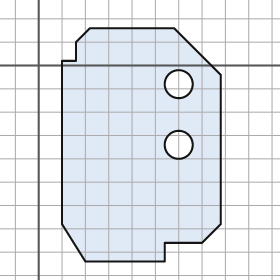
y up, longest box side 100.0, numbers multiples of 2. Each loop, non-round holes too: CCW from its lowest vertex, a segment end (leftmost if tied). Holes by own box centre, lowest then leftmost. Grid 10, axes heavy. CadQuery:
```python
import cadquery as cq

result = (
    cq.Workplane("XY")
    .moveTo(20.0, -84.0)
    .lineTo(54.0, -84.0)
    .lineTo(54.0, -76.0)
    .lineTo(70.0, -76.0)
    .lineTo(78.0, -68.0)
    .lineTo(78.0, -4.0)
    .lineTo(58.0, 16.0)
    .lineTo(22.0, 16.0)
    .lineTo(16.0, 10.0)
    .lineTo(16.0, 2.0)
    .lineTo(10.0, 2.0)
    .lineTo(10.0, -68.0)
    .close()
    .moveTo(60.0, -34.0)
    .circle(6.0)
    .moveTo(60.0, -8.0)
    .circle(6.0)
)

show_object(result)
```